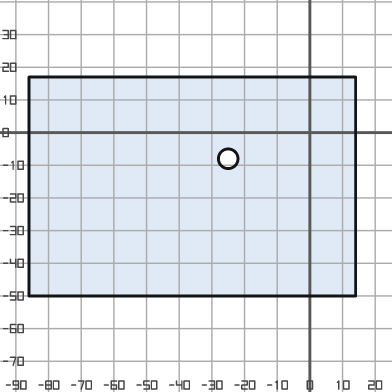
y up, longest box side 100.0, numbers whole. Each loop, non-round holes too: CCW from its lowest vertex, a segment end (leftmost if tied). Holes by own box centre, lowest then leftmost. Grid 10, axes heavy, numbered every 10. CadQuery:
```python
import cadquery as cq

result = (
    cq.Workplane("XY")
    .moveTo(-86.0, -50.0)
    .lineTo(14.0, -50.0)
    .lineTo(14.0, 17.0)
    .lineTo(-86.0, 17.0)
    .close()
    .moveTo(-25.0, -8.0)
    .circle(3.0)
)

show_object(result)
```